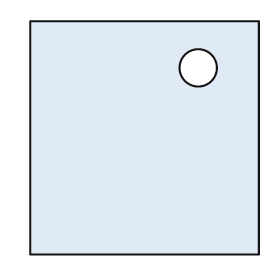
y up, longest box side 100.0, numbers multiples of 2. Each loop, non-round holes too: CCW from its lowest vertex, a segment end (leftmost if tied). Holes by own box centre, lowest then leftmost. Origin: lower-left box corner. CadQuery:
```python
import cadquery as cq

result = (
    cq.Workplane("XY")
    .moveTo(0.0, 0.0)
    .lineTo(98.0, 0.0)
    .lineTo(98.0, 100.0)
    .lineTo(0.0, 100.0)
    .close()
    .moveTo(72.0, 80.0)
    .circle(8.0)
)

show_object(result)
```